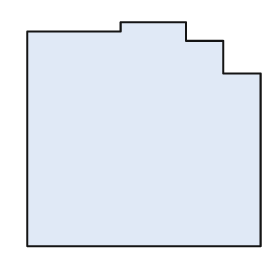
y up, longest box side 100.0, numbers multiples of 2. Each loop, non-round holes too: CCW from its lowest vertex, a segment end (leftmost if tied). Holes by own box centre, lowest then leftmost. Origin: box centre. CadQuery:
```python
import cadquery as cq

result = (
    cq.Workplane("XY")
    .moveTo(-50.0, -48.0)
    .lineTo(50.0, -48.0)
    .lineTo(50.0, 26.0)
    .lineTo(34.0, 26.0)
    .lineTo(34.0, 40.0)
    .lineTo(18.0, 40.0)
    .lineTo(18.0, 48.0)
    .lineTo(-10.0, 48.0)
    .lineTo(-10.0, 44.0)
    .lineTo(-50.0, 44.0)
    .close()
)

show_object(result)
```